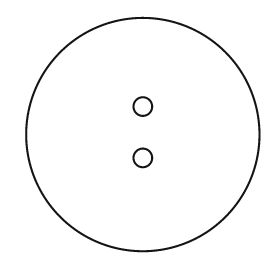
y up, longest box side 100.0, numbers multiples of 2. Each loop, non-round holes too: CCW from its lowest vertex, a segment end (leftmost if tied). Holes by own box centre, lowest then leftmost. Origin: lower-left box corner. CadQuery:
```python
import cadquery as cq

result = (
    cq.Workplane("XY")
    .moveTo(50.0, 50.0)
    .circle(50.0)
    .moveTo(50.0, 40.0)
    .circle(4.0)
    .moveTo(50.0, 62.0)
    .circle(4.0)
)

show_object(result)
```